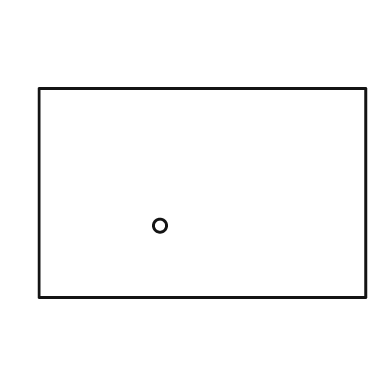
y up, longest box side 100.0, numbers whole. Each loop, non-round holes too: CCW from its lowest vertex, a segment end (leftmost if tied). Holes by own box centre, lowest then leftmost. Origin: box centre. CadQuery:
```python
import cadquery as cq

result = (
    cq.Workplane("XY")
    .moveTo(-50.0, -32.0)
    .lineTo(50.0, -32.0)
    .lineTo(50.0, 32.0)
    .lineTo(-50.0, 32.0)
    .close()
    .moveTo(-13.0, -10.0)
    .circle(2.0)
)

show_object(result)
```